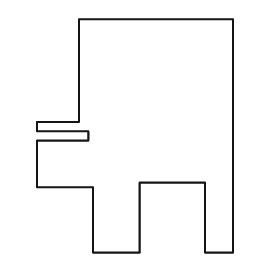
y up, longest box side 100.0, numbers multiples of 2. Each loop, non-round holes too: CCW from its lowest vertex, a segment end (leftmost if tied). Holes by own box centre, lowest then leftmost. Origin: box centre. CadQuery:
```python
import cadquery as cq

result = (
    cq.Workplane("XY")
    .moveTo(-18.0, -50.0)
    .lineTo(2.0, -50.0)
    .lineTo(2.0, -20.0)
    .lineTo(30.0, -20.0)
    .lineTo(30.0, -50.0)
    .lineTo(42.0, -50.0)
    .lineTo(42.0, 50.0)
    .lineTo(-24.0, 50.0)
    .lineTo(-24.0, 6.0)
    .lineTo(-42.0, 6.0)
    .lineTo(-42.0, 2.0)
    .lineTo(-20.0, 2.0)
    .lineTo(-20.0, -2.0)
    .lineTo(-42.0, -2.0)
    .lineTo(-42.0, -22.0)
    .lineTo(-18.0, -22.0)
    .close()
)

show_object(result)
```